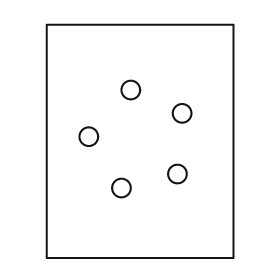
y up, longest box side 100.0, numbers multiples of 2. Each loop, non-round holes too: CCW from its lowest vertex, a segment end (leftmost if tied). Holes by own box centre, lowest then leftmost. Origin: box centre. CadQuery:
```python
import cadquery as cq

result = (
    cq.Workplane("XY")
    .moveTo(-40.0, -50.0)
    .lineTo(40.0, -50.0)
    .lineTo(40.0, 50.0)
    .lineTo(-40.0, 50.0)
    .close()
    .moveTo(-8.0, -20.0)
    .circle(4.0)
    .moveTo(16.0, -14.0)
    .circle(4.0)
    .moveTo(-22.0, 2.0)
    .circle(4.0)
    .moveTo(18.0, 12.0)
    .circle(4.0)
    .moveTo(-4.0, 22.0)
    .circle(4.0)
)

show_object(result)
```